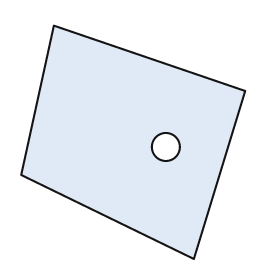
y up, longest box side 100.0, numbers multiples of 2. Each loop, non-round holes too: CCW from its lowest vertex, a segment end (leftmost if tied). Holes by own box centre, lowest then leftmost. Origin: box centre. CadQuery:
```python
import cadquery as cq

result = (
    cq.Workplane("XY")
    .moveTo(26.0, -50.0)
    .lineTo(48.0, 22.0)
    .lineTo(-34.0, 50.0)
    .lineTo(-48.0, -14.0)
    .close()
    .moveTo(14.0, -2.0)
    .circle(6.0)
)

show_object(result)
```